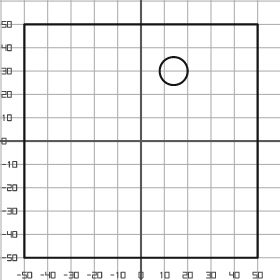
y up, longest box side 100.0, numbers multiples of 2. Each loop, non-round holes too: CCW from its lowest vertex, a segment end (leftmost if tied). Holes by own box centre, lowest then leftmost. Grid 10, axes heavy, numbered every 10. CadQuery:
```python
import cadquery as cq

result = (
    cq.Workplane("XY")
    .moveTo(-50.0, -50.0)
    .lineTo(50.0, -50.0)
    .lineTo(50.0, 50.0)
    .lineTo(-50.0, 50.0)
    .close()
    .moveTo(14.0, 30.0)
    .circle(6.0)
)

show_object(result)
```